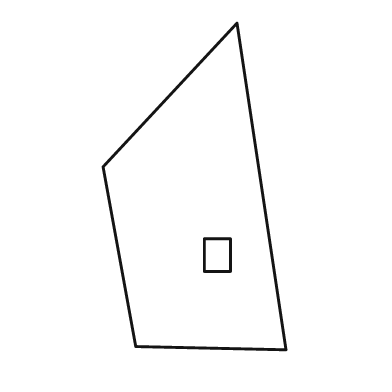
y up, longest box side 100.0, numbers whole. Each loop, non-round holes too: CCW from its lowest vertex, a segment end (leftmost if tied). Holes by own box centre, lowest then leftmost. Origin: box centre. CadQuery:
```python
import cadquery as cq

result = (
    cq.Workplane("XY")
    .moveTo(28.0, -50.0)
    .lineTo(13.0, 50.0)
    .lineTo(-28.0, 6.0)
    .lineTo(-18.0, -49.0)
    .close()
    .moveTo(3.0, -26.0)
    .lineTo(11.0, -26.0)
    .lineTo(11.0, -16.0)
    .lineTo(3.0, -16.0)
    .close()
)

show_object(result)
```